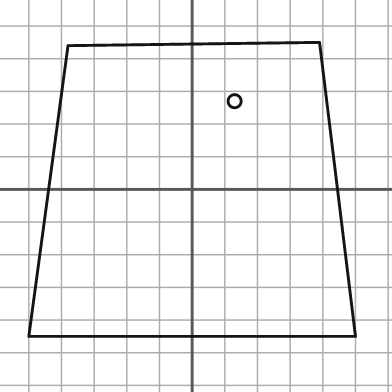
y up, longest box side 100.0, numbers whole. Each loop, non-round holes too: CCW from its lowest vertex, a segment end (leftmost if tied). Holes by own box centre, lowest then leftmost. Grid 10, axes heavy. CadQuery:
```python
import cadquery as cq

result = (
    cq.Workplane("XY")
    .moveTo(-50.0, -45.0)
    .lineTo(50.0, -45.0)
    .lineTo(39.0, 45.0)
    .lineTo(-38.0, 44.0)
    .close()
    .moveTo(13.0, 27.0)
    .circle(2.0)
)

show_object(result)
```